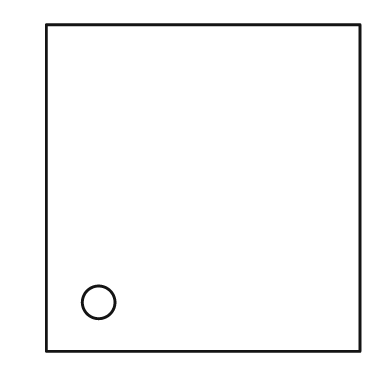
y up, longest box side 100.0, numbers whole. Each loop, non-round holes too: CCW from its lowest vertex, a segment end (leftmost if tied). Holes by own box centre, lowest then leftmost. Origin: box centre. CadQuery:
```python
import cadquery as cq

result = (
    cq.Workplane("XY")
    .moveTo(-48.0, -50.0)
    .lineTo(48.0, -50.0)
    .lineTo(48.0, 50.0)
    .lineTo(-48.0, 50.0)
    .close()
    .moveTo(-32.0, -35.0)
    .circle(5.0)
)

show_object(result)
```